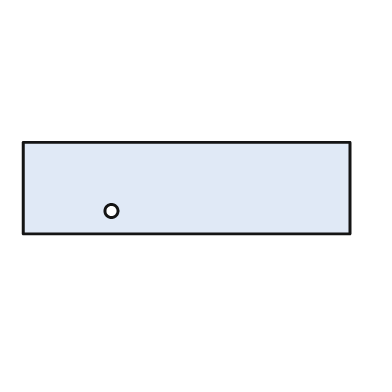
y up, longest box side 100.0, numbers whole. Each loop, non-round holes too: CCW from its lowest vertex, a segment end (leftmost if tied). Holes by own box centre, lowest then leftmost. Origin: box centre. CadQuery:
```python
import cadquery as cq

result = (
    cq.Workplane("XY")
    .moveTo(-50.0, -14.0)
    .lineTo(50.0, -14.0)
    .lineTo(50.0, 14.0)
    .lineTo(-50.0, 14.0)
    .close()
    .moveTo(-23.0, -7.0)
    .circle(2.0)
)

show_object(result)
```